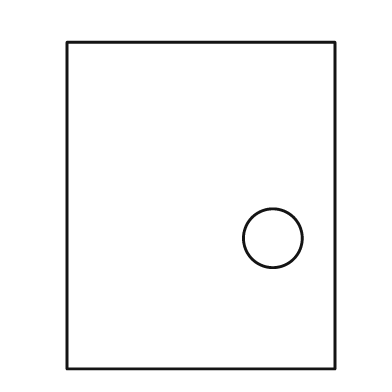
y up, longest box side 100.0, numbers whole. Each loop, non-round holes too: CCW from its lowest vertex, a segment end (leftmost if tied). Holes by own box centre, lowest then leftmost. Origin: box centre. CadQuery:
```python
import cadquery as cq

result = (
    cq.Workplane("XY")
    .moveTo(-41.0, -50.0)
    .lineTo(41.0, -50.0)
    .lineTo(41.0, 50.0)
    .lineTo(-41.0, 50.0)
    .close()
    .moveTo(22.0, -10.0)
    .circle(9.0)
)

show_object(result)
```